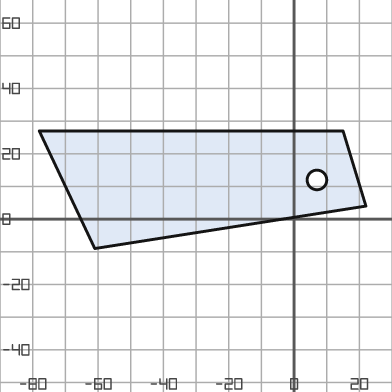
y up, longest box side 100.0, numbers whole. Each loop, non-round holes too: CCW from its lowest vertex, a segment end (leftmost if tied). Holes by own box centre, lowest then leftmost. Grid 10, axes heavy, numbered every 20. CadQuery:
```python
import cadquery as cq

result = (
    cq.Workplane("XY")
    .moveTo(-61.0, -9.0)
    .lineTo(22.0, 4.0)
    .lineTo(15.0, 27.0)
    .lineTo(-78.0, 27.0)
    .close()
    .moveTo(7.0, 12.0)
    .circle(3.0)
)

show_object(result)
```